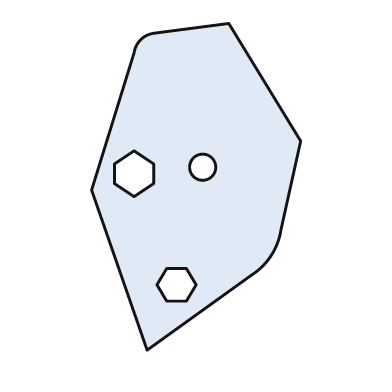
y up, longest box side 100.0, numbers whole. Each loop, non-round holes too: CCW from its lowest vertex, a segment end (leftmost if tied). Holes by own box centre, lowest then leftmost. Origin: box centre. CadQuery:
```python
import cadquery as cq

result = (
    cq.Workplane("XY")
    .moveTo(-15.0, -50.0)
    .lineTo(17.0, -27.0)
    .threePointArc((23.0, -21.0), (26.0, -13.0))
    .lineTo(32.0, 14.0)
    .lineTo(10.0, 50.0)
    .lineTo(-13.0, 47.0)
    .threePointArc((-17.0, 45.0), (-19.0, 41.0))
    .lineTo(-32.0, -1.0)
    .close()
    .moveTo(-9.0, -35.0)
    .lineTo(-3.0, -35.0)
    .lineTo(0.0, -30.0)
    .lineTo(-3.0, -25.0)
    .lineTo(-9.0, -25.0)
    .lineTo(-12.0, -30.0)
    .close()
    .moveTo(-19.0, -3.0)
    .lineTo(-13.0, 1.0)
    .lineTo(-13.0, 7.0)
    .lineTo(-19.0, 11.0)
    .lineTo(-25.0, 7.0)
    .lineTo(-25.0, 1.0)
    .close()
    .moveTo(2.0, 6.0)
    .circle(4.0)
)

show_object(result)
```